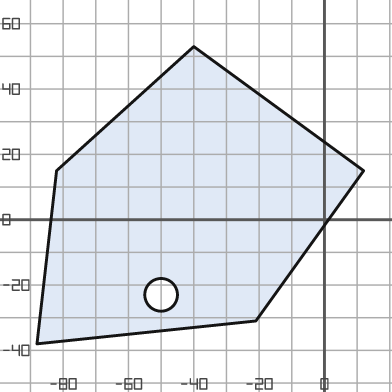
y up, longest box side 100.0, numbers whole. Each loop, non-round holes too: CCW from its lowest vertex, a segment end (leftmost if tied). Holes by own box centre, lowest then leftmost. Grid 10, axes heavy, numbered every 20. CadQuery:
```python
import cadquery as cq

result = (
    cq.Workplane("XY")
    .moveTo(-88.0, -38.0)
    .lineTo(-21.0, -31.0)
    .lineTo(12.0, 15.0)
    .lineTo(-40.0, 53.0)
    .lineTo(-82.0, 15.0)
    .close()
    .moveTo(-50.0, -23.0)
    .circle(5.0)
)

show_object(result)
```